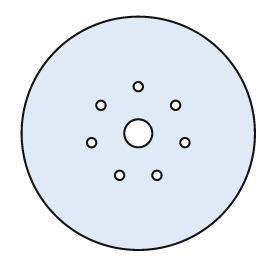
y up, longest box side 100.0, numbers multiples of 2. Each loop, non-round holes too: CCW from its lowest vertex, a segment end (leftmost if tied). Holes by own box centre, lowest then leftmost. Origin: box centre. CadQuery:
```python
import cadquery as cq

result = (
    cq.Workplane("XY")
    .moveTo(0.0, 0.0)
    .circle(50.0)
    .moveTo(-8.0, -18.0)
    .circle(2.0)
    .moveTo(8.0, -18.0)
    .circle(2.0)
    .moveTo(-20.0, -4.0)
    .circle(2.0)
    .moveTo(20.0, -4.0)
    .circle(2.0)
    .moveTo(0.0, 0.0)
    .circle(6.0)
    .moveTo(-16.0, 12.0)
    .circle(2.0)
    .moveTo(16.0, 12.0)
    .circle(2.0)
    .moveTo(0.0, 20.0)
    .circle(2.0)
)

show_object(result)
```